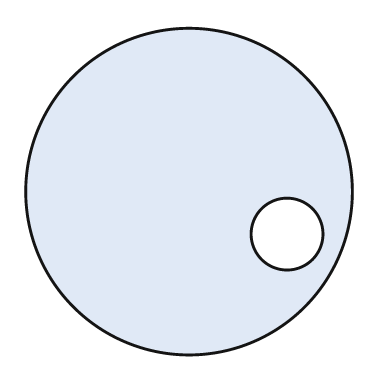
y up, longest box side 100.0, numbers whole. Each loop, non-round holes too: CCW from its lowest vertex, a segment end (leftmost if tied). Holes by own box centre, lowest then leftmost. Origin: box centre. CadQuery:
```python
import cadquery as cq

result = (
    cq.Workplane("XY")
    .moveTo(0.0, 0.0)
    .circle(50.0)
    .moveTo(30.0, -13.0)
    .circle(11.0)
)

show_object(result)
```